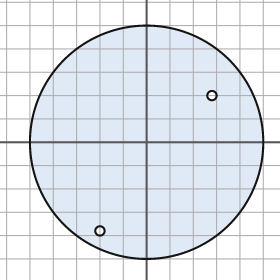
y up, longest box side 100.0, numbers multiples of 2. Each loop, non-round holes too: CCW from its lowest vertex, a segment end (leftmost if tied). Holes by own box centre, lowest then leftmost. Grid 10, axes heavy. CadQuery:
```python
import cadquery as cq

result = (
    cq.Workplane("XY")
    .moveTo(0.0, 0.0)
    .circle(50.0)
    .moveTo(-20.0, -38.0)
    .circle(2.0)
    .moveTo(28.0, 20.0)
    .circle(2.0)
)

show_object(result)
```